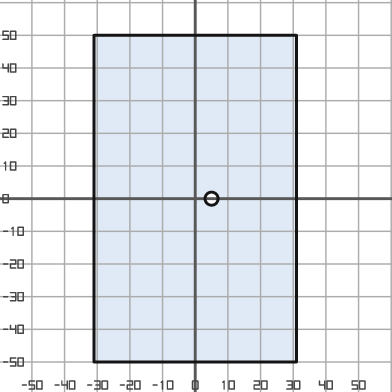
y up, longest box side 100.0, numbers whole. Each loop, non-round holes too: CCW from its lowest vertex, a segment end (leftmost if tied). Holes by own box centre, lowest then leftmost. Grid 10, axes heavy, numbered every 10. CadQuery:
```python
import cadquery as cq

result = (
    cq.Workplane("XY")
    .moveTo(-31.0, -50.0)
    .lineTo(31.0, -50.0)
    .lineTo(31.0, 50.0)
    .lineTo(-31.0, 50.0)
    .close()
    .moveTo(5.0, 0.0)
    .circle(2.0)
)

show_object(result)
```